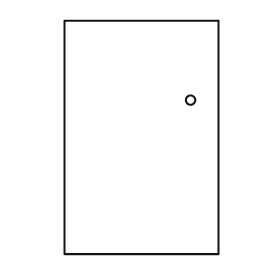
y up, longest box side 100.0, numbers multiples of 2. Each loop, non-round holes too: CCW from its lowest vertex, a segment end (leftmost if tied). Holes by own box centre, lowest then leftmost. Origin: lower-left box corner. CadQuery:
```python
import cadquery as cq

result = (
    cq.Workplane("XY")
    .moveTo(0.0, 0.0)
    .lineTo(66.0, 0.0)
    .lineTo(66.0, 100.0)
    .lineTo(0.0, 100.0)
    .close()
    .moveTo(54.0, 66.0)
    .circle(2.0)
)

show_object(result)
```